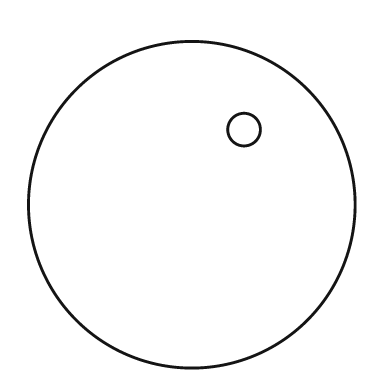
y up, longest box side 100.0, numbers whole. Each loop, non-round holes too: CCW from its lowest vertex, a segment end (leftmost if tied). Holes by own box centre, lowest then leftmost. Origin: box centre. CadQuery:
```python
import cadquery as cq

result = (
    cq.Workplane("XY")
    .moveTo(0.0, 0.0)
    .circle(50.0)
    .moveTo(16.0, 23.0)
    .circle(5.0)
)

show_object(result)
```